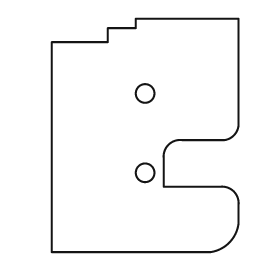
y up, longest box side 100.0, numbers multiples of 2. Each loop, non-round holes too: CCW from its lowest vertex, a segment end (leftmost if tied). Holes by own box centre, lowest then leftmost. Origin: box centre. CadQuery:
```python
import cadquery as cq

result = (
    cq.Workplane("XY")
    .moveTo(-40.0, -50.0)
    .lineTo(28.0, -50.0)
    .threePointArc((36.0, -46.0), (40.0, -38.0))
    .lineTo(40.0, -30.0)
    .threePointArc((38.0, -24.0), (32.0, -22.0))
    .lineTo(8.0, -22.0)
    .lineTo(8.0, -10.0)
    .threePointArc((10.0, -4.0), (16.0, -2.0))
    .lineTo(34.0, -2.0)
    .threePointArc((38.0, 0.0), (40.0, 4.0))
    .lineTo(40.0, 50.0)
    .lineTo(-4.0, 50.0)
    .lineTo(-4.0, 46.0)
    .lineTo(-16.0, 46.0)
    .lineTo(-16.0, 40.0)
    .lineTo(-40.0, 40.0)
    .close()
    .moveTo(0.0, -16.0)
    .circle(4.0)
    .moveTo(0.0, 18.0)
    .circle(4.0)
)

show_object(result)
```